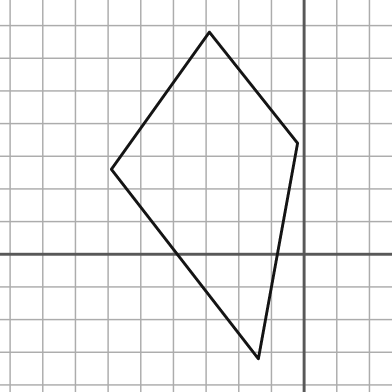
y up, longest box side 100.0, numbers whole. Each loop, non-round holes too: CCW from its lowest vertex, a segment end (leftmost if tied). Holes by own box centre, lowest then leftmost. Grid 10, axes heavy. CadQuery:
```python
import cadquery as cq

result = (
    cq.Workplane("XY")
    .moveTo(-14.0, -32.0)
    .lineTo(-2.0, 34.0)
    .lineTo(-29.0, 68.0)
    .lineTo(-59.0, 26.0)
    .close()
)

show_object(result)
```